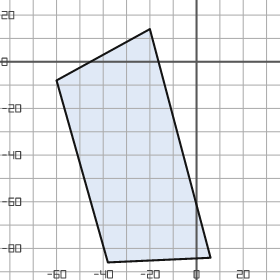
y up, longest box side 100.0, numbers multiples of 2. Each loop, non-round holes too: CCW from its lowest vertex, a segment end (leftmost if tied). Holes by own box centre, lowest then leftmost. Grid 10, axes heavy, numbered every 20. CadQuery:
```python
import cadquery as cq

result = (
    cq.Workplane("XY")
    .moveTo(-38.0, -86.0)
    .lineTo(6.0, -84.0)
    .lineTo(-20.0, 14.0)
    .lineTo(-60.0, -8.0)
    .close()
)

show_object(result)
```